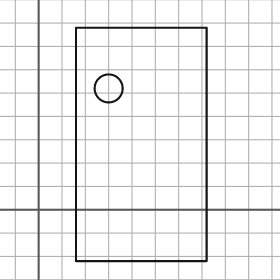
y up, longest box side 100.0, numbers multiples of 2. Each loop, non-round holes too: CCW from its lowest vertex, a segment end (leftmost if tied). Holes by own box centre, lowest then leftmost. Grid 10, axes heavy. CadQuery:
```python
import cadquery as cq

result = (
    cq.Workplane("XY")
    .moveTo(16.0, -22.0)
    .lineTo(72.0, -22.0)
    .lineTo(72.0, 78.0)
    .lineTo(16.0, 78.0)
    .close()
    .moveTo(30.0, 52.0)
    .circle(6.0)
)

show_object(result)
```